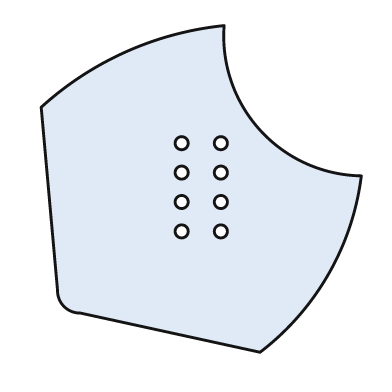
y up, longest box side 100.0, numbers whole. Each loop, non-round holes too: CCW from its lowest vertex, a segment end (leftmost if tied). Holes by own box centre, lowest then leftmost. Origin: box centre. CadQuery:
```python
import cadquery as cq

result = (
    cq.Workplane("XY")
    .moveTo(18.0, -50.0)
    .threePointArc((39.0, -26.0), (49.0, 4.0))
    .threePointArc((18.0, 18.0), (7.0, 50.0))
    .threePointArc((-23.0, 42.0), (-49.0, 25.0))
    .lineTo(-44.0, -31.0)
    .threePointArc((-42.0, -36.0), (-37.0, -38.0))
    .close()
    .moveTo(-6.0, -13.0)
    .circle(2.0)
    .moveTo(6.0, -13.0)
    .circle(2.0)
    .moveTo(-6.0, -4.0)
    .circle(2.0)
    .moveTo(6.0, -4.0)
    .circle(2.0)
    .moveTo(-6.0, 5.0)
    .circle(2.0)
    .moveTo(6.0, 5.0)
    .circle(2.0)
    .moveTo(-6.0, 14.0)
    .circle(2.0)
    .moveTo(6.0, 14.0)
    .circle(2.0)
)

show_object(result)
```